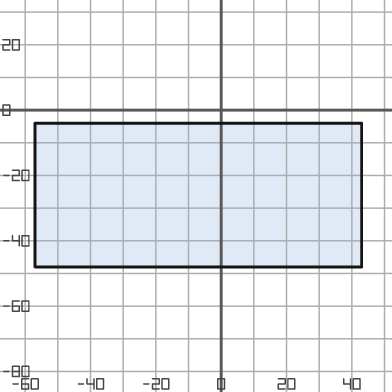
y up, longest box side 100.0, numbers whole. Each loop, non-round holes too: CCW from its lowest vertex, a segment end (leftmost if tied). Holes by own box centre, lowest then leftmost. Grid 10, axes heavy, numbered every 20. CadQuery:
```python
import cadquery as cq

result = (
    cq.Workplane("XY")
    .moveTo(-57.0, -48.0)
    .lineTo(43.0, -48.0)
    .lineTo(43.0, -4.0)
    .lineTo(-57.0, -4.0)
    .close()
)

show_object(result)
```